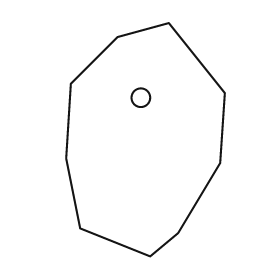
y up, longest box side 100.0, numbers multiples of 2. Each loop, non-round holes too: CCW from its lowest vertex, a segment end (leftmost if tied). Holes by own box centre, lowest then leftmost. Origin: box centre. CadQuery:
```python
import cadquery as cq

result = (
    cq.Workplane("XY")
    .moveTo(2.0, -50.0)
    .lineTo(14.0, -40.0)
    .lineTo(32.0, -10.0)
    .lineTo(34.0, 20.0)
    .lineTo(10.0, 50.0)
    .lineTo(-12.0, 44.0)
    .lineTo(-32.0, 24.0)
    .lineTo(-34.0, -8.0)
    .lineTo(-28.0, -38.0)
    .close()
    .moveTo(-2.0, 18.0)
    .circle(4.0)
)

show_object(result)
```